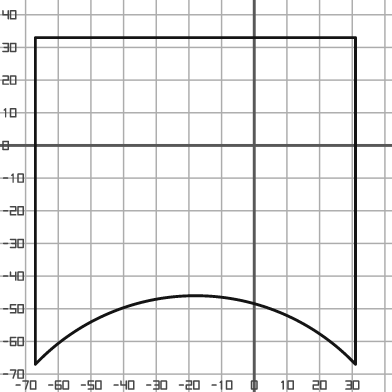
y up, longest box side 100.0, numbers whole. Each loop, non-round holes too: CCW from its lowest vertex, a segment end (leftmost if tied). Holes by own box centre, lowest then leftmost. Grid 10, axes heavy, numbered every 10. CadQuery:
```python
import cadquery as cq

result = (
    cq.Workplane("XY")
    .moveTo(-67.0, -67.0)
    .threePointArc((-18.0, -46.0), (31.0, -67.0))
    .lineTo(31.0, 33.0)
    .lineTo(-67.0, 33.0)
    .close()
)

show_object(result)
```